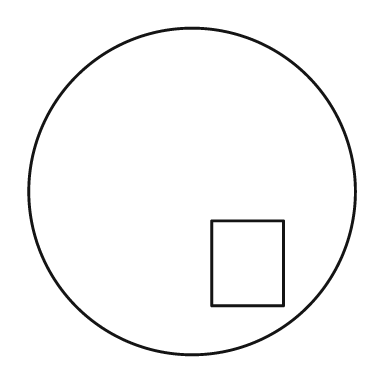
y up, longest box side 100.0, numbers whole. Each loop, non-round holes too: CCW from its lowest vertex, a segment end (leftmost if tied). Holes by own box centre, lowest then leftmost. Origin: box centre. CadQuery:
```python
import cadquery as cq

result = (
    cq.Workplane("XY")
    .moveTo(0.0, 0.0)
    .circle(50.0)
    .moveTo(6.0, -35.0)
    .lineTo(28.0, -35.0)
    .lineTo(28.0, -9.0)
    .lineTo(6.0, -9.0)
    .close()
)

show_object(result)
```